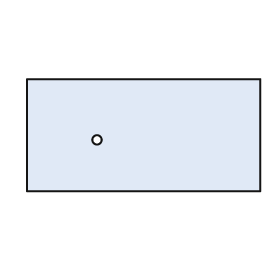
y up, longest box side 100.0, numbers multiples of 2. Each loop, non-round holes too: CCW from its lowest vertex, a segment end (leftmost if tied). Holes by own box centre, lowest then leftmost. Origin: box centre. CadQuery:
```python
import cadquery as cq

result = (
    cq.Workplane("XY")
    .moveTo(-50.0, -24.0)
    .lineTo(50.0, -24.0)
    .lineTo(50.0, 24.0)
    .lineTo(-50.0, 24.0)
    .close()
    .moveTo(-20.0, -2.0)
    .circle(2.0)
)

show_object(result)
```